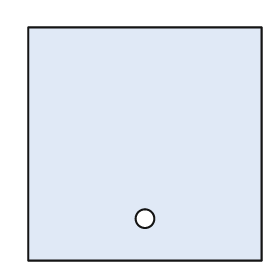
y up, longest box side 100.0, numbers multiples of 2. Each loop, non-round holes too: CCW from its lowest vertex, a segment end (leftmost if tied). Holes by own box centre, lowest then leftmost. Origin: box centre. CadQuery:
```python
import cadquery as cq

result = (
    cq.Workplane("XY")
    .moveTo(-50.0, -50.0)
    .lineTo(50.0, -50.0)
    .lineTo(50.0, 50.0)
    .lineTo(-50.0, 50.0)
    .close()
    .moveTo(0.0, -32.0)
    .circle(4.0)
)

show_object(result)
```